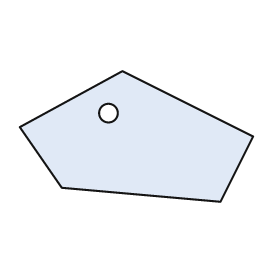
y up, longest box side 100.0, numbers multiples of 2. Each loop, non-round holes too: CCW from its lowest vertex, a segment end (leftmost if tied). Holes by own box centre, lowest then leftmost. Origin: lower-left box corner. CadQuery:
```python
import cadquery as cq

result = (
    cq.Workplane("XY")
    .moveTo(86.0, 0.0)
    .lineTo(100.0, 28.0)
    .lineTo(44.0, 56.0)
    .lineTo(0.0, 32.0)
    .lineTo(18.0, 6.0)
    .close()
    .moveTo(38.0, 38.0)
    .circle(4.0)
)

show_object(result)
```